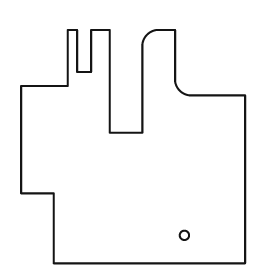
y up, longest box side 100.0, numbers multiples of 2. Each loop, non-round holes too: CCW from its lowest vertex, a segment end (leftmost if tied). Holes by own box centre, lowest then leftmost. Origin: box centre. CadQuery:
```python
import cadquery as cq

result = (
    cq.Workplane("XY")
    .moveTo(-34.0, -50.0)
    .lineTo(48.0, -50.0)
    .lineTo(48.0, 22.0)
    .lineTo(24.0, 22.0)
    .threePointArc((20.0, 24.0), (18.0, 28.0))
    .lineTo(18.0, 50.0)
    .lineTo(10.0, 50.0)
    .threePointArc((6.0, 48.0), (4.0, 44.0))
    .lineTo(4.0, 6.0)
    .lineTo(-10.0, 6.0)
    .lineTo(-10.0, 50.0)
    .lineTo(-18.0, 50.0)
    .lineTo(-18.0, 32.0)
    .lineTo(-24.0, 32.0)
    .lineTo(-24.0, 50.0)
    .lineTo(-28.0, 50.0)
    .lineTo(-28.0, 26.0)
    .lineTo(-48.0, 26.0)
    .lineTo(-48.0, -20.0)
    .lineTo(-34.0, -20.0)
    .close()
    .moveTo(22.0, -38.0)
    .circle(2.0)
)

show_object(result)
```